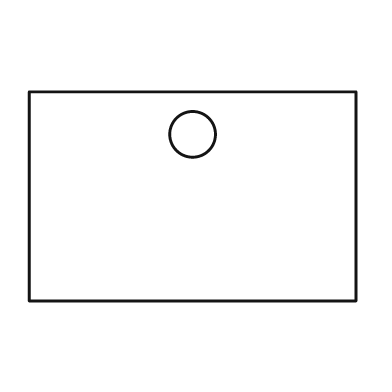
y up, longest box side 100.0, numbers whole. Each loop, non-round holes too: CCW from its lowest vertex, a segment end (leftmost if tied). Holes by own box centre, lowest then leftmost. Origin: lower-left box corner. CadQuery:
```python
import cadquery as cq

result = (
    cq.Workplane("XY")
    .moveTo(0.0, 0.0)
    .lineTo(100.0, 0.0)
    .lineTo(100.0, 64.0)
    .lineTo(0.0, 64.0)
    .close()
    .moveTo(50.0, 51.0)
    .circle(7.0)
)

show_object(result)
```